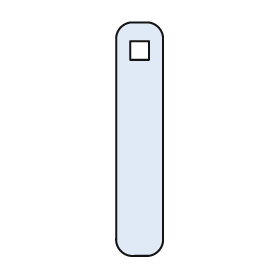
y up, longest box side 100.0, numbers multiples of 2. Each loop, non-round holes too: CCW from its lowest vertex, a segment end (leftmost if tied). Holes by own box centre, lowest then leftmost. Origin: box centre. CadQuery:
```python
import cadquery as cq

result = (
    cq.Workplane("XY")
    .moveTo(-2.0, -50.0)
    .lineTo(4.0, -50.0)
    .threePointArc((8.0, -48.0), (10.0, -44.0))
    .lineTo(10.0, 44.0)
    .threePointArc((8.0, 48.0), (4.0, 50.0))
    .lineTo(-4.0, 50.0)
    .threePointArc((-8.0, 48.0), (-10.0, 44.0))
    .lineTo(-10.0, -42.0)
    .threePointArc((-8.0, -48.0), (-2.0, -50.0))
    .close()
    .moveTo(-4.0, 34.0)
    .lineTo(4.0, 34.0)
    .lineTo(4.0, 42.0)
    .lineTo(-4.0, 42.0)
    .close()
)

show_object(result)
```